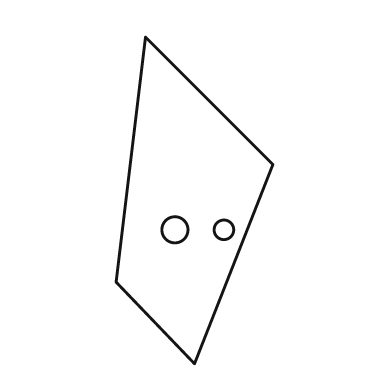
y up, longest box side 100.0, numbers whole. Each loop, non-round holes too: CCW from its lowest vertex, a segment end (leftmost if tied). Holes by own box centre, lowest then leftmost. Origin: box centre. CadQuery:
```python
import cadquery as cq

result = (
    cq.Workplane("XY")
    .moveTo(0.0, -50.0)
    .lineTo(24.0, 11.0)
    .lineTo(-15.0, 50.0)
    .lineTo(-24.0, -25.0)
    .close()
    .moveTo(-6.0, -9.0)
    .circle(4.0)
    .moveTo(9.0, -9.0)
    .circle(3.0)
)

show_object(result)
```